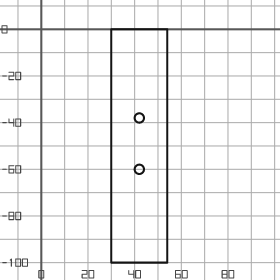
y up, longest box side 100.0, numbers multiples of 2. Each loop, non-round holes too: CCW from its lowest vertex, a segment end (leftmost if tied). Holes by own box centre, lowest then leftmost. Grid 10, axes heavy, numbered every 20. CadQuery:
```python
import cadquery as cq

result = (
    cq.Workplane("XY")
    .moveTo(30.0, -100.0)
    .lineTo(54.0, -100.0)
    .lineTo(54.0, 0.0)
    .lineTo(30.0, 0.0)
    .close()
    .moveTo(42.0, -60.0)
    .circle(2.0)
    .moveTo(42.0, -38.0)
    .circle(2.0)
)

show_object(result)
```